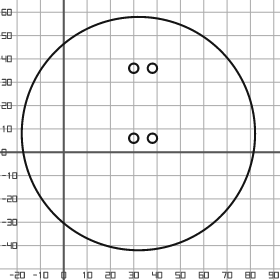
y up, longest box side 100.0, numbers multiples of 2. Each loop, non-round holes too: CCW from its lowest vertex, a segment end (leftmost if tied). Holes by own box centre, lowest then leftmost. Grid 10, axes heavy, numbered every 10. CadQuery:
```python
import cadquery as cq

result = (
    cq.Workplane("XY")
    .moveTo(32.0, 8.0)
    .circle(50.0)
    .moveTo(30.0, 6.0)
    .circle(2.0)
    .moveTo(38.0, 6.0)
    .circle(2.0)
    .moveTo(30.0, 36.0)
    .circle(2.0)
    .moveTo(38.0, 36.0)
    .circle(2.0)
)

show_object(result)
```